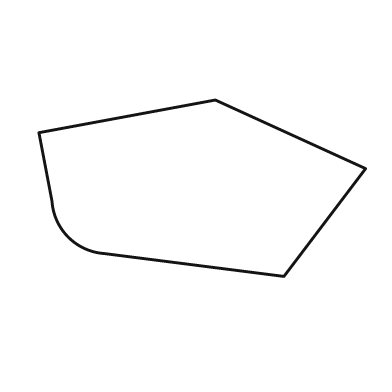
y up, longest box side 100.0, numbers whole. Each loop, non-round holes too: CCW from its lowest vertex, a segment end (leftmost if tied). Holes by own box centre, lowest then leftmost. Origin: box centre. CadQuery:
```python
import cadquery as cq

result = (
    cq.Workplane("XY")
    .moveTo(25.0, -27.0)
    .lineTo(50.0, 6.0)
    .lineTo(4.0, 27.0)
    .lineTo(-50.0, 17.0)
    .lineTo(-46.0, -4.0)
    .threePointArc((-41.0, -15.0), (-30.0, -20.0))
    .close()
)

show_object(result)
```